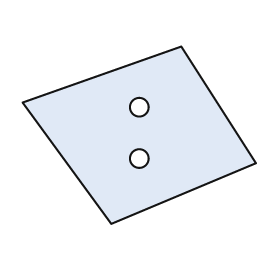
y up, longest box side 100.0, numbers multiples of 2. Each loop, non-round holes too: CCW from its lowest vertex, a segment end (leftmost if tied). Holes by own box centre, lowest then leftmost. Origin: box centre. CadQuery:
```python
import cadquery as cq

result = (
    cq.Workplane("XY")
    .moveTo(-12.0, -38.0)
    .lineTo(50.0, -12.0)
    .lineTo(18.0, 38.0)
    .lineTo(-50.0, 14.0)
    .close()
    .moveTo(0.0, -10.0)
    .circle(4.0)
    .moveTo(0.0, 12.0)
    .circle(4.0)
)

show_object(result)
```